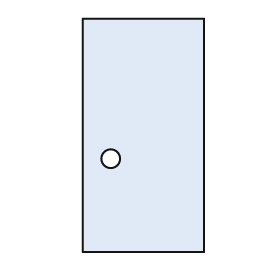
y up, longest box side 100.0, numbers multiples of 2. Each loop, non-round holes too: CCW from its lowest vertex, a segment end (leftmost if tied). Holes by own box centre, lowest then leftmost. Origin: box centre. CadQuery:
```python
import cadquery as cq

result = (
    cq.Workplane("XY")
    .moveTo(-26.0, -50.0)
    .lineTo(26.0, -50.0)
    .lineTo(26.0, 50.0)
    .lineTo(-26.0, 50.0)
    .close()
    .moveTo(-14.0, -10.0)
    .circle(4.0)
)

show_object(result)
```